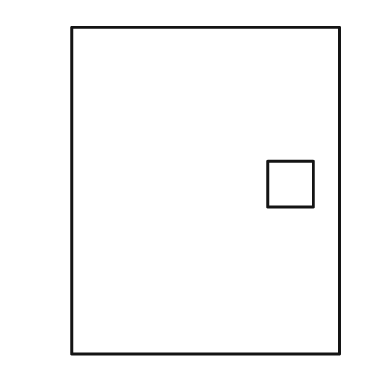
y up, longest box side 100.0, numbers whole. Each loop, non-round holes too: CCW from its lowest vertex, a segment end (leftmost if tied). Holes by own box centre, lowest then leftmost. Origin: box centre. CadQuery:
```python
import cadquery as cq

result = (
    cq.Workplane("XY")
    .moveTo(-41.0, -50.0)
    .lineTo(41.0, -50.0)
    .lineTo(41.0, 50.0)
    .lineTo(-41.0, 50.0)
    .close()
    .moveTo(19.0, -5.0)
    .lineTo(33.0, -5.0)
    .lineTo(33.0, 9.0)
    .lineTo(19.0, 9.0)
    .close()
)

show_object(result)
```